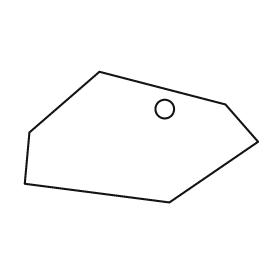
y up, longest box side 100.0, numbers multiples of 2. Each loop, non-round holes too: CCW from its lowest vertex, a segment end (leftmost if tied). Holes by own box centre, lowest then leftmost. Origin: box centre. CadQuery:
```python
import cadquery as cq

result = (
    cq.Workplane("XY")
    .moveTo(12.0, -28.0)
    .lineTo(50.0, -2.0)
    .lineTo(36.0, 14.0)
    .lineTo(-18.0, 28.0)
    .lineTo(-48.0, 2.0)
    .lineTo(-50.0, -20.0)
    .close()
    .moveTo(10.0, 12.0)
    .circle(4.0)
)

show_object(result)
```